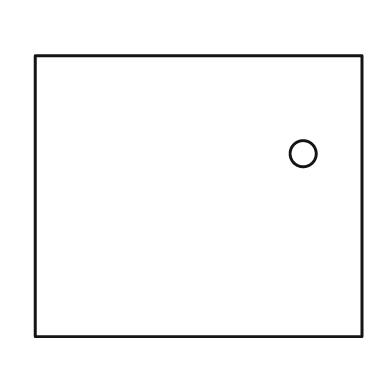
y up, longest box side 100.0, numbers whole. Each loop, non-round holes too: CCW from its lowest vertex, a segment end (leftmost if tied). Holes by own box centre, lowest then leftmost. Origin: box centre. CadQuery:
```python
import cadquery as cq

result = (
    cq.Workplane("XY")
    .moveTo(-50.0, -43.0)
    .lineTo(50.0, -43.0)
    .lineTo(50.0, 43.0)
    .lineTo(-50.0, 43.0)
    .close()
    .moveTo(32.0, 13.0)
    .circle(4.0)
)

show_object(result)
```